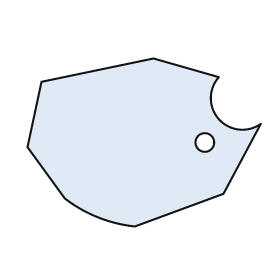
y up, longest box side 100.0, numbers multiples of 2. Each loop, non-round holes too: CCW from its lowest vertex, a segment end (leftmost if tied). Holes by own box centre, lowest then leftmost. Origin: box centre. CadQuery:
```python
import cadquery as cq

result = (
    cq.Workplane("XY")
    .moveTo(-4.0, -36.0)
    .lineTo(34.0, -22.0)
    .lineTo(50.0, 8.0)
    .threePointArc((32.0, 10.0), (32.0, 28.0))
    .lineTo(4.0, 36.0)
    .lineTo(-44.0, 26.0)
    .lineTo(-50.0, -2.0)
    .lineTo(-34.0, -24.0)
    .threePointArc((-20.0, -32.0), (-4.0, -36.0))
    .close()
    .moveTo(26.0, 0.0)
    .circle(4.0)
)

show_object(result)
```